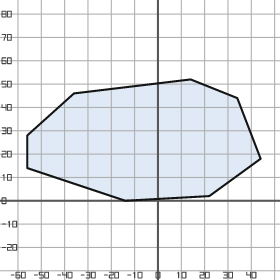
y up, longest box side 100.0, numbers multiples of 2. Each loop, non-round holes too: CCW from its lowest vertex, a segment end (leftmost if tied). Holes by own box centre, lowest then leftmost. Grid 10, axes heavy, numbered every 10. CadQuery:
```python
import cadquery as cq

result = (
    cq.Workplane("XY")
    .moveTo(-14.0, 0.0)
    .lineTo(22.0, 2.0)
    .lineTo(44.0, 18.0)
    .lineTo(34.0, 44.0)
    .lineTo(14.0, 52.0)
    .lineTo(-36.0, 46.0)
    .lineTo(-56.0, 28.0)
    .lineTo(-56.0, 14.0)
    .close()
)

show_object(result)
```